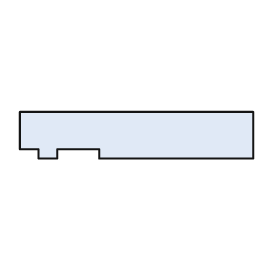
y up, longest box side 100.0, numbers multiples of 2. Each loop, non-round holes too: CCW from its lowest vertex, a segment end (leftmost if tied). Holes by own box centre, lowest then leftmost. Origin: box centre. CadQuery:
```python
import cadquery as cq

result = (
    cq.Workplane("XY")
    .moveTo(-42.0, -10.0)
    .lineTo(-34.0, -10.0)
    .lineTo(-34.0, -6.0)
    .lineTo(-16.0, -6.0)
    .lineTo(-16.0, -10.0)
    .lineTo(50.0, -10.0)
    .lineTo(50.0, 10.0)
    .lineTo(-50.0, 10.0)
    .lineTo(-50.0, -6.0)
    .lineTo(-42.0, -6.0)
    .close()
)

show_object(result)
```